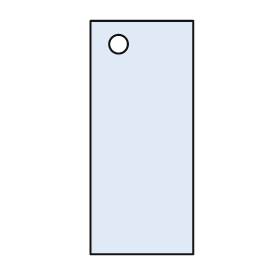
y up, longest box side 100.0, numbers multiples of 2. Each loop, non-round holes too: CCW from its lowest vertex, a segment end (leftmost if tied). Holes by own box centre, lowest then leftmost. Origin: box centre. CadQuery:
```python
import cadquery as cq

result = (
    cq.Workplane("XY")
    .moveTo(-22.0, -50.0)
    .lineTo(22.0, -50.0)
    .lineTo(22.0, 50.0)
    .lineTo(-22.0, 50.0)
    .close()
    .moveTo(-10.0, 40.0)
    .circle(4.0)
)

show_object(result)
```